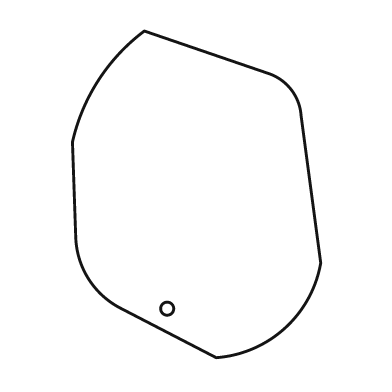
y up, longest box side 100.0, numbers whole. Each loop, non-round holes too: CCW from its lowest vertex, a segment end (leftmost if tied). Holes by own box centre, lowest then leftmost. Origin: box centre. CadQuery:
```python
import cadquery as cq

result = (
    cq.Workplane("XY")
    .moveTo(6.0, -50.0)
    .threePointArc((27.0, -41.0), (38.0, -21.0))
    .lineTo(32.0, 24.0)
    .threePointArc((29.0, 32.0), (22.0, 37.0))
    .lineTo(-16.0, 50.0)
    .threePointArc((-30.0, 35.0), (-38.0, 16.0))
    .lineTo(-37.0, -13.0)
    .threePointArc((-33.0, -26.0), (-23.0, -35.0))
    .close()
    .moveTo(-9.0, -35.0)
    .circle(2.0)
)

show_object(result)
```